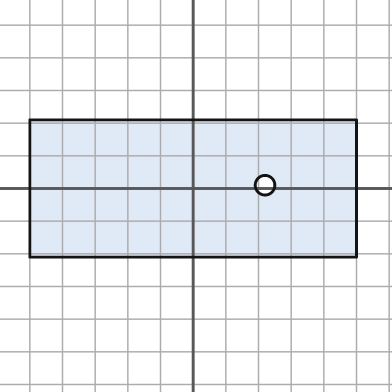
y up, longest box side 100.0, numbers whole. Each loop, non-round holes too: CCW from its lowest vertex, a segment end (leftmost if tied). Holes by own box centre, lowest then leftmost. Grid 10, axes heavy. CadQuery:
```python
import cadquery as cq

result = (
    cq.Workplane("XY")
    .moveTo(-50.0, -21.0)
    .lineTo(50.0, -21.0)
    .lineTo(50.0, 21.0)
    .lineTo(-50.0, 21.0)
    .close()
    .moveTo(22.0, 1.0)
    .circle(3.0)
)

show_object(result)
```